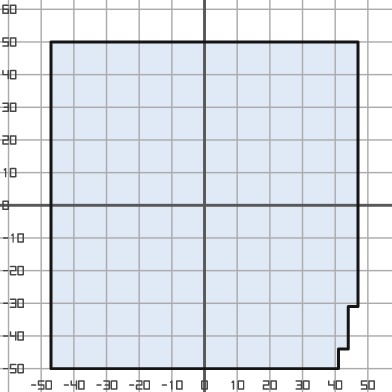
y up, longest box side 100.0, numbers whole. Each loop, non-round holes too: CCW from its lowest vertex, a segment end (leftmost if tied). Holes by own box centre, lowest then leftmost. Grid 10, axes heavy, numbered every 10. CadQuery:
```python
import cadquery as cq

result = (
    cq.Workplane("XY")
    .moveTo(-47.0, -50.0)
    .lineTo(41.0, -50.0)
    .lineTo(41.0, -44.0)
    .lineTo(44.0, -44.0)
    .lineTo(44.0, -31.0)
    .lineTo(47.0, -31.0)
    .lineTo(47.0, 50.0)
    .lineTo(-47.0, 50.0)
    .close()
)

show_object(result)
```